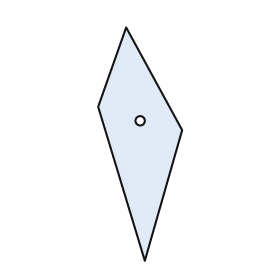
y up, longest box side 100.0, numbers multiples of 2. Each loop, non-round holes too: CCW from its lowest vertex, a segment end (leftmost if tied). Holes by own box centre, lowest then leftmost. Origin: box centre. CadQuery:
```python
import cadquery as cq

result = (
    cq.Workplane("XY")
    .moveTo(2.0, -50.0)
    .lineTo(18.0, 6.0)
    .lineTo(-6.0, 50.0)
    .lineTo(-18.0, 16.0)
    .close()
    .moveTo(0.0, 10.0)
    .circle(2.0)
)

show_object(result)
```